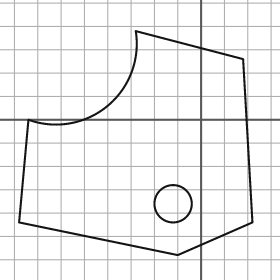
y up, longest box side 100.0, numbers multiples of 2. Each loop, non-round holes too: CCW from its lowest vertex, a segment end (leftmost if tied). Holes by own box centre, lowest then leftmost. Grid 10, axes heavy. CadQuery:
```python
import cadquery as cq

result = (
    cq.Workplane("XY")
    .moveTo(-10.0, -58.0)
    .lineTo(22.0, -44.0)
    .lineTo(18.0, 26.0)
    .lineTo(-28.0, 38.0)
    .threePointArc((-40.0, 6.0), (-74.0, 0.0))
    .lineTo(-78.0, -44.0)
    .close()
    .moveTo(-12.0, -36.0)
    .circle(8.0)
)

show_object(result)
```